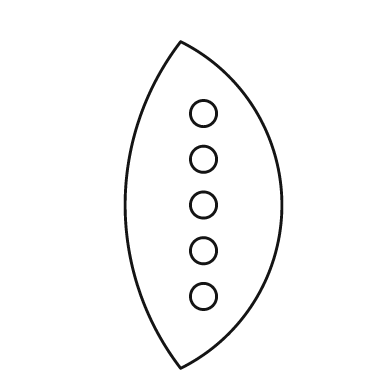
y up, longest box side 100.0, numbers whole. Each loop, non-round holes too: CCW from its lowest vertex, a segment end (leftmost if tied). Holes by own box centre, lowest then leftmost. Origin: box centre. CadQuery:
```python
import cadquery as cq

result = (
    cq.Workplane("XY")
    .moveTo(-7.0, -50.0)
    .threePointArc((24.0, 0.0), (-7.0, 50.0))
    .threePointArc((-24.0, 0.0), (-7.0, -50.0))
    .close()
    .moveTo(0.0, -28.0)
    .circle(4.0)
    .moveTo(0.0, -14.0)
    .circle(4.0)
    .moveTo(0.0, 0.0)
    .circle(4.0)
    .moveTo(0.0, 14.0)
    .circle(4.0)
    .moveTo(0.0, 28.0)
    .circle(4.0)
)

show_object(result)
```